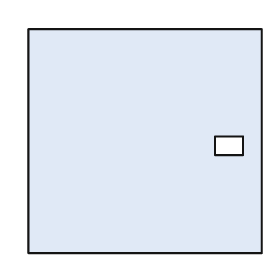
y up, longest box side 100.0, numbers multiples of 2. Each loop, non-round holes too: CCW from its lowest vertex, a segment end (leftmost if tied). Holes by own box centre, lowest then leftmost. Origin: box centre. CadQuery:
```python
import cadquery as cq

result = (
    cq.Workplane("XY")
    .moveTo(-50.0, -48.0)
    .lineTo(50.0, -48.0)
    .lineTo(50.0, 48.0)
    .lineTo(-50.0, 48.0)
    .close()
    .moveTo(30.0, -6.0)
    .lineTo(42.0, -6.0)
    .lineTo(42.0, 2.0)
    .lineTo(30.0, 2.0)
    .close()
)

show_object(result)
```